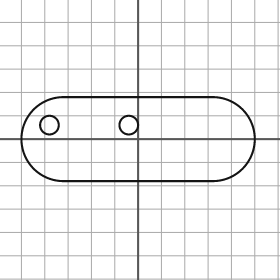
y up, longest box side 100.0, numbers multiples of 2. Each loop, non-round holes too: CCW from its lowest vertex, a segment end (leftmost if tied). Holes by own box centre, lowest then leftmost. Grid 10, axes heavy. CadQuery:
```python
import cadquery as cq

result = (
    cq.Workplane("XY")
    .moveTo(-32.0, -18.0)
    .lineTo(32.0, -18.0)
    .threePointArc((50.0, 0.0), (32.0, 18.0))
    .lineTo(-32.0, 18.0)
    .threePointArc((-50.0, 0.0), (-32.0, -18.0))
    .close()
    .moveTo(-38.0, 6.0)
    .circle(4.0)
    .moveTo(-4.0, 6.0)
    .circle(4.0)
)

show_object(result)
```